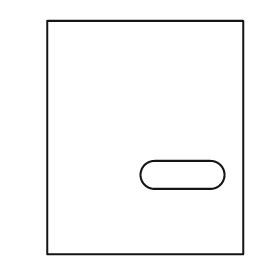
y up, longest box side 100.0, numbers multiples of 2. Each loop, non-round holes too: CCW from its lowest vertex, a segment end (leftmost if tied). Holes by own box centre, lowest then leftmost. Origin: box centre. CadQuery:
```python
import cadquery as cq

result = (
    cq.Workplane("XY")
    .moveTo(-42.0, -50.0)
    .lineTo(42.0, -50.0)
    .lineTo(42.0, 50.0)
    .lineTo(-42.0, 50.0)
    .close()
    .moveTo(4.0, -22.0)
    .lineTo(28.0, -22.0)
    .threePointArc((34.0, -16.0), (28.0, -10.0))
    .lineTo(4.0, -10.0)
    .threePointArc((-2.0, -16.0), (4.0, -22.0))
    .close()
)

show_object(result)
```